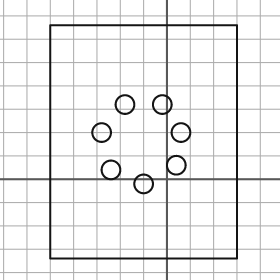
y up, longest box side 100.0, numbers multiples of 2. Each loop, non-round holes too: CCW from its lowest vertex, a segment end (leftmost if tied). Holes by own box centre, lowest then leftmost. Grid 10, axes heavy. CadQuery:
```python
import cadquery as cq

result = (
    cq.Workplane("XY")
    .moveTo(-50.0, -34.0)
    .lineTo(30.0, -34.0)
    .lineTo(30.0, 66.0)
    .lineTo(-50.0, 66.0)
    .close()
    .moveTo(-10.0, -2.0)
    .circle(4.0)
    .moveTo(-24.0, 4.0)
    .circle(4.0)
    .moveTo(4.0, 6.0)
    .circle(4.0)
    .moveTo(-28.0, 20.0)
    .circle(4.0)
    .moveTo(6.0, 20.0)
    .circle(4.0)
    .moveTo(-18.0, 32.0)
    .circle(4.0)
    .moveTo(-2.0, 32.0)
    .circle(4.0)
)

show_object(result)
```